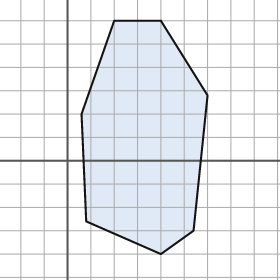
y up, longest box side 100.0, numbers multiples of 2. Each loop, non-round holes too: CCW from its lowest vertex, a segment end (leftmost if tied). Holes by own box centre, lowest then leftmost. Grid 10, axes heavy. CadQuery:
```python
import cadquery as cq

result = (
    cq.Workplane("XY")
    .moveTo(40.0, -40.0)
    .lineTo(54.0, -30.0)
    .lineTo(60.0, 28.0)
    .lineTo(40.0, 60.0)
    .lineTo(20.0, 60.0)
    .lineTo(6.0, 20.0)
    .lineTo(8.0, -26.0)
    .close()
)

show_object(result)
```